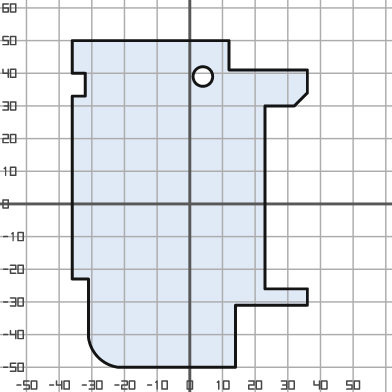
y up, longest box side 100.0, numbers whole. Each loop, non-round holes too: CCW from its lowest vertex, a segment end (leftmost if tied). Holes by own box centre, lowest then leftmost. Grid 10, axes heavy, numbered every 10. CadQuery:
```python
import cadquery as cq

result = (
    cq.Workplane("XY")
    .moveTo(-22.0, -50.0)
    .lineTo(14.0, -50.0)
    .lineTo(14.0, -31.0)
    .lineTo(36.0, -31.0)
    .lineTo(36.0, -26.0)
    .lineTo(23.0, -26.0)
    .lineTo(23.0, 30.0)
    .lineTo(32.0, 30.0)
    .lineTo(36.0, 34.0)
    .lineTo(36.0, 41.0)
    .lineTo(12.0, 41.0)
    .lineTo(12.0, 50.0)
    .lineTo(-36.0, 50.0)
    .lineTo(-36.0, 40.0)
    .lineTo(-32.0, 40.0)
    .lineTo(-32.0, 33.0)
    .lineTo(-36.0, 33.0)
    .lineTo(-36.0, -23.0)
    .lineTo(-31.0, -23.0)
    .lineTo(-31.0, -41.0)
    .threePointArc((-28.0, -47.0), (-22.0, -50.0))
    .close()
    .moveTo(4.0, 39.0)
    .circle(3.0)
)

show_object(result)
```